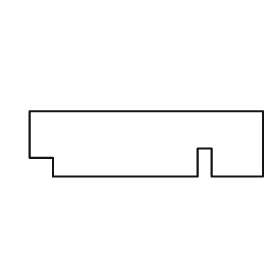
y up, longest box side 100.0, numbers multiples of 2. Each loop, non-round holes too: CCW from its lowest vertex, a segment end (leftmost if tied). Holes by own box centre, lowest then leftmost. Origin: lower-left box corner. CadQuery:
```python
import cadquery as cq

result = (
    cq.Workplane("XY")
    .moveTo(10.0, 0.0)
    .lineTo(72.0, 0.0)
    .lineTo(72.0, 12.0)
    .lineTo(78.0, 12.0)
    .lineTo(78.0, 0.0)
    .lineTo(100.0, 0.0)
    .lineTo(100.0, 28.0)
    .lineTo(0.0, 28.0)
    .lineTo(0.0, 8.0)
    .lineTo(10.0, 8.0)
    .close()
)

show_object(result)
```